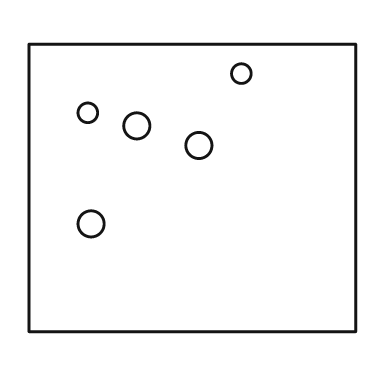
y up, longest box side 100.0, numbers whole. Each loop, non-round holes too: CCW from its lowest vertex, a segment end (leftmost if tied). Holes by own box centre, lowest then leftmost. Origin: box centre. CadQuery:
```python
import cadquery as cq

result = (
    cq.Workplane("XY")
    .moveTo(-50.0, -44.0)
    .lineTo(50.0, -44.0)
    .lineTo(50.0, 44.0)
    .lineTo(-50.0, 44.0)
    .close()
    .moveTo(-31.0, -11.0)
    .circle(4.0)
    .moveTo(2.0, 13.0)
    .circle(4.0)
    .moveTo(-17.0, 19.0)
    .circle(4.0)
    .moveTo(-32.0, 23.0)
    .circle(3.0)
    .moveTo(15.0, 35.0)
    .circle(3.0)
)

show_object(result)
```